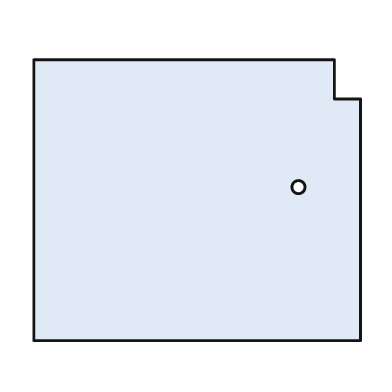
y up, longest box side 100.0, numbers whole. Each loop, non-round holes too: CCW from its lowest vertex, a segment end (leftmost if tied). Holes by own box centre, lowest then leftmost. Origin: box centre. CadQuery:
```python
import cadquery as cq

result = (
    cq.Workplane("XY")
    .moveTo(-50.0, -43.0)
    .lineTo(50.0, -43.0)
    .lineTo(50.0, 31.0)
    .lineTo(42.0, 31.0)
    .lineTo(42.0, 43.0)
    .lineTo(-50.0, 43.0)
    .close()
    .moveTo(31.0, 4.0)
    .circle(2.0)
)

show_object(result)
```